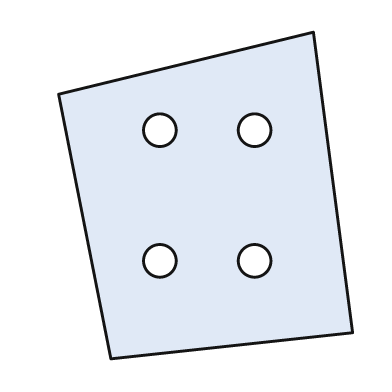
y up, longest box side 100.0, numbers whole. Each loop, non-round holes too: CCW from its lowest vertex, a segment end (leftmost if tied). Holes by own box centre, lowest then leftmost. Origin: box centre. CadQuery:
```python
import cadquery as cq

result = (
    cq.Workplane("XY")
    .moveTo(-29.0, -50.0)
    .lineTo(45.0, -42.0)
    .lineTo(33.0, 50.0)
    .lineTo(-45.0, 31.0)
    .close()
    .moveTo(-14.0, -20.0)
    .circle(5.0)
    .moveTo(15.0, -20.0)
    .circle(5.0)
    .moveTo(-14.0, 20.0)
    .circle(5.0)
    .moveTo(15.0, 20.0)
    .circle(5.0)
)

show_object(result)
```